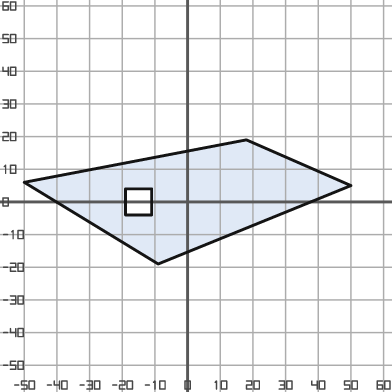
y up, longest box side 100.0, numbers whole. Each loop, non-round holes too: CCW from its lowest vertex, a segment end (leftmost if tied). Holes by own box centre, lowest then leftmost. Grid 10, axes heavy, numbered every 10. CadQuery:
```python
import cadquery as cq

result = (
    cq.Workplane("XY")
    .moveTo(-9.0, -19.0)
    .lineTo(50.0, 5.0)
    .lineTo(18.0, 19.0)
    .lineTo(-50.0, 6.0)
    .close()
    .moveTo(-19.0, -4.0)
    .lineTo(-11.0, -4.0)
    .lineTo(-11.0, 4.0)
    .lineTo(-19.0, 4.0)
    .close()
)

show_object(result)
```